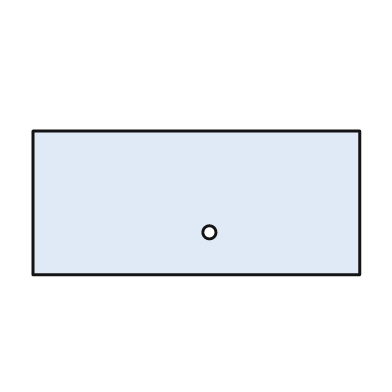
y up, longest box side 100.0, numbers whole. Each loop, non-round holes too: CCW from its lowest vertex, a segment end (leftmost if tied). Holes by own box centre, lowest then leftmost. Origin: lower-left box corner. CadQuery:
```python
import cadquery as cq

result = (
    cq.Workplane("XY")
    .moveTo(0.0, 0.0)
    .lineTo(100.0, 0.0)
    .lineTo(100.0, 44.0)
    .lineTo(0.0, 44.0)
    .close()
    .moveTo(54.0, 13.0)
    .circle(2.0)
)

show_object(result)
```